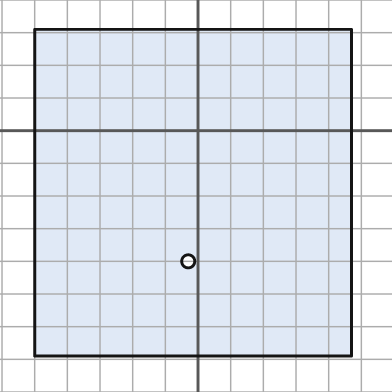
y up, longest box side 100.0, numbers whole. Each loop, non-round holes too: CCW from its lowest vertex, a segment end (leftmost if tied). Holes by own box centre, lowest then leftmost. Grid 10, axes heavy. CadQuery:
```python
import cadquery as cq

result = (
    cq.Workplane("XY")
    .moveTo(-50.0, -69.0)
    .lineTo(47.0, -69.0)
    .lineTo(47.0, 31.0)
    .lineTo(-50.0, 31.0)
    .close()
    .moveTo(-3.0, -40.0)
    .circle(2.0)
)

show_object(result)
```